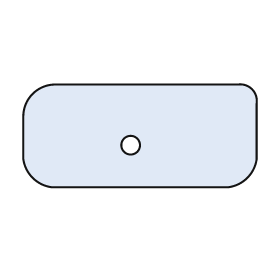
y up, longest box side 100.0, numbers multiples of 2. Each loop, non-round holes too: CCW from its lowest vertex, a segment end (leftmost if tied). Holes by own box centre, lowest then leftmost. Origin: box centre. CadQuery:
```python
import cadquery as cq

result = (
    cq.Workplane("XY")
    .moveTo(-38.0, -22.0)
    .lineTo(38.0, -22.0)
    .threePointArc((46.0, -18.0), (50.0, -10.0))
    .lineTo(50.0, 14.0)
    .threePointArc((48.0, 20.0), (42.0, 22.0))
    .lineTo(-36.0, 22.0)
    .threePointArc((-46.0, 18.0), (-50.0, 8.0))
    .lineTo(-50.0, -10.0)
    .threePointArc((-46.0, -18.0), (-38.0, -22.0))
    .close()
    .moveTo(-4.0, -4.0)
    .circle(4.0)
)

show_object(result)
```